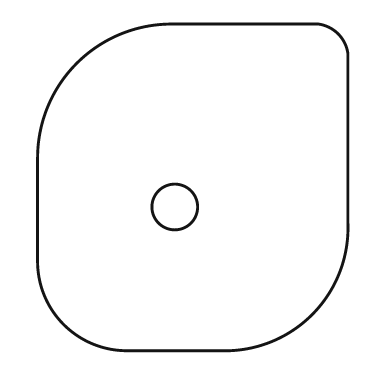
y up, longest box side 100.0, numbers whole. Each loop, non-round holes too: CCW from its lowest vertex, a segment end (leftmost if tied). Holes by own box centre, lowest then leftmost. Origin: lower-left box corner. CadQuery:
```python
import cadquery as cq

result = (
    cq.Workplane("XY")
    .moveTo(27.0, 0.0)
    .lineTo(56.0, 0.0)
    .threePointArc((84.0, 11.0), (95.0, 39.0))
    .lineTo(95.0, 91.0)
    .threePointArc((92.0, 97.0), (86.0, 100.0))
    .lineTo(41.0, 100.0)
    .threePointArc((12.0, 88.0), (0.0, 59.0))
    .lineTo(0.0, 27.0)
    .threePointArc((8.0, 8.0), (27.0, 0.0))
    .close()
    .moveTo(42.0, 44.0)
    .circle(7.0)
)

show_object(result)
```